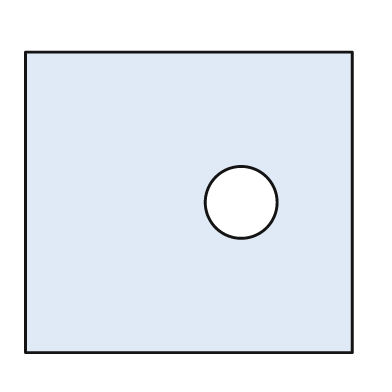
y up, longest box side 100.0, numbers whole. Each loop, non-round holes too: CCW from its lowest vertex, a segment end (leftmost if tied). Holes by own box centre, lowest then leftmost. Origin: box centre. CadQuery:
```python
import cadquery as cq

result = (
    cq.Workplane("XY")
    .moveTo(-50.0, -46.0)
    .lineTo(50.0, -46.0)
    .lineTo(50.0, 46.0)
    .lineTo(-50.0, 46.0)
    .close()
    .moveTo(16.0, 0.0)
    .circle(11.0)
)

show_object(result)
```